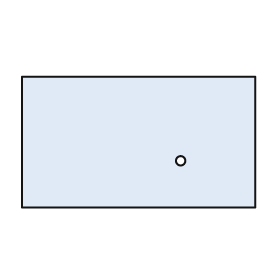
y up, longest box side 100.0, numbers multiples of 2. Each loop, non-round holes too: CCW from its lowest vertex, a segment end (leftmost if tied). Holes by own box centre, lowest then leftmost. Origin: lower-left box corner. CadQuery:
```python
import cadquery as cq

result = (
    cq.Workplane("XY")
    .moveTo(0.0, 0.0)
    .lineTo(100.0, 0.0)
    .lineTo(100.0, 56.0)
    .lineTo(0.0, 56.0)
    .close()
    .moveTo(68.0, 20.0)
    .circle(2.0)
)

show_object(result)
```